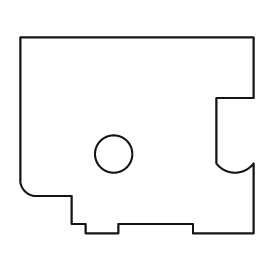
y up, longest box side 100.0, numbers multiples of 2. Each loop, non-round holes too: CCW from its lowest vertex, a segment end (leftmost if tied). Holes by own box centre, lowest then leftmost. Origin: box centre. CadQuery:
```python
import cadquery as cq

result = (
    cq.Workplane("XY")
    .moveTo(-22.0, -42.0)
    .lineTo(-8.0, -42.0)
    .lineTo(-8.0, -38.0)
    .lineTo(24.0, -38.0)
    .lineTo(24.0, -42.0)
    .lineTo(50.0, -42.0)
    .lineTo(50.0, -12.0)
    .threePointArc((42.0, -16.0), (34.0, -12.0))
    .lineTo(34.0, 16.0)
    .lineTo(50.0, 16.0)
    .lineTo(50.0, 42.0)
    .lineTo(-50.0, 42.0)
    .lineTo(-50.0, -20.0)
    .threePointArc((-48.0, -24.0), (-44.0, -26.0))
    .lineTo(-28.0, -26.0)
    .lineTo(-28.0, -38.0)
    .lineTo(-22.0, -38.0)
    .close()
    .moveTo(-10.0, -8.0)
    .circle(8.0)
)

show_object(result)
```